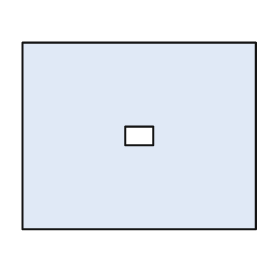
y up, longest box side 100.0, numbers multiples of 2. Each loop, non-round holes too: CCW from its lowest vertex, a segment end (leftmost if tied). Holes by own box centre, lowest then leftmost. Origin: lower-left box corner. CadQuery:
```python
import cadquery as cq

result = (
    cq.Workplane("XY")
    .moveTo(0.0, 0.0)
    .lineTo(100.0, 0.0)
    .lineTo(100.0, 80.0)
    .lineTo(0.0, 80.0)
    .close()
    .moveTo(44.0, 36.0)
    .lineTo(56.0, 36.0)
    .lineTo(56.0, 44.0)
    .lineTo(44.0, 44.0)
    .close()
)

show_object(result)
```